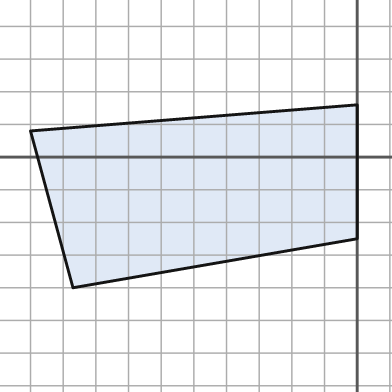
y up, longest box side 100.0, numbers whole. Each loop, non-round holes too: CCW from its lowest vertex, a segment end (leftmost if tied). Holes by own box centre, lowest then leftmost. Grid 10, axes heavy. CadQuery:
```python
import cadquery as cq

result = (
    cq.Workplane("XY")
    .moveTo(-87.0, -40.0)
    .lineTo(0.0, -25.0)
    .lineTo(0.0, 16.0)
    .lineTo(-100.0, 8.0)
    .close()
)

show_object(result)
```